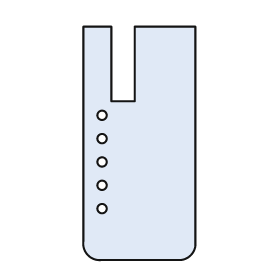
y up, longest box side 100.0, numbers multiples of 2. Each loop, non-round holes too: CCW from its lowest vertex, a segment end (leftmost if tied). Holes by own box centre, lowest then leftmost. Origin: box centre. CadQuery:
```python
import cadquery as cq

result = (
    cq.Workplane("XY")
    .moveTo(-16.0, -50.0)
    .lineTo(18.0, -50.0)
    .threePointArc((22.0, -48.0), (24.0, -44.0))
    .lineTo(24.0, 50.0)
    .lineTo(-2.0, 50.0)
    .lineTo(-2.0, 18.0)
    .lineTo(-12.0, 18.0)
    .lineTo(-12.0, 50.0)
    .lineTo(-24.0, 50.0)
    .lineTo(-24.0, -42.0)
    .threePointArc((-22.0, -48.0), (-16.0, -50.0))
    .close()
    .moveTo(-16.0, -28.0)
    .circle(2.0)
    .moveTo(-16.0, -18.0)
    .circle(2.0)
    .moveTo(-16.0, -8.0)
    .circle(2.0)
    .moveTo(-16.0, 2.0)
    .circle(2.0)
    .moveTo(-16.0, 12.0)
    .circle(2.0)
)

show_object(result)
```